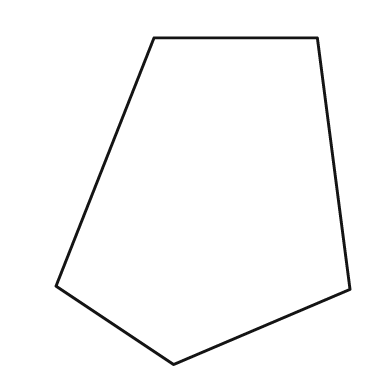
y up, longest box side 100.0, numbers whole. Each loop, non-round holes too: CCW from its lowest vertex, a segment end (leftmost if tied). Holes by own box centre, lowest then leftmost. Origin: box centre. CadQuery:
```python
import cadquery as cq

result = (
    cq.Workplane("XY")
    .moveTo(-9.0, -50.0)
    .lineTo(45.0, -27.0)
    .lineTo(35.0, 50.0)
    .lineTo(-15.0, 50.0)
    .lineTo(-45.0, -26.0)
    .close()
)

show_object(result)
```